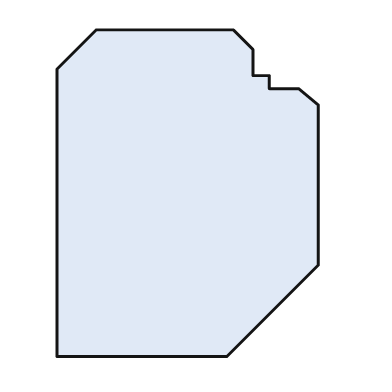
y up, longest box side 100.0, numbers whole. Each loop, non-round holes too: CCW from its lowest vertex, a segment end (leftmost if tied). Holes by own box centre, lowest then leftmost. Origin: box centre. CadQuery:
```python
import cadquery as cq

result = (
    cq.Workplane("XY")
    .moveTo(-40.0, -50.0)
    .lineTo(12.0, -50.0)
    .lineTo(40.0, -22.0)
    .lineTo(40.0, 27.0)
    .lineTo(34.0, 32.0)
    .lineTo(25.0, 32.0)
    .lineTo(25.0, 36.0)
    .lineTo(20.0, 36.0)
    .lineTo(20.0, 44.0)
    .lineTo(14.0, 50.0)
    .lineTo(-28.0, 50.0)
    .lineTo(-40.0, 38.0)
    .close()
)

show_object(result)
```